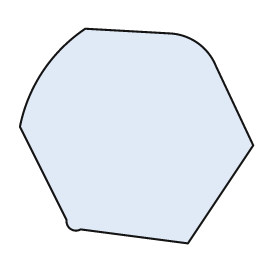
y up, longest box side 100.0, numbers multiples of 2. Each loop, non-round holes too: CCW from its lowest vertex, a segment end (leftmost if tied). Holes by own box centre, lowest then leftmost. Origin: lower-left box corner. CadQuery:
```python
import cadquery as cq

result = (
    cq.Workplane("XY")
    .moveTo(72.0, 0.0)
    .lineTo(100.0, 42.0)
    .lineTo(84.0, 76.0)
    .threePointArc((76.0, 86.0), (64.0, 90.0))
    .lineTo(28.0, 92.0)
    .threePointArc((10.0, 74.0), (0.0, 50.0))
    .lineTo(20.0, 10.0)
    .threePointArc((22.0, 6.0), (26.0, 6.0))
    .close()
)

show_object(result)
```